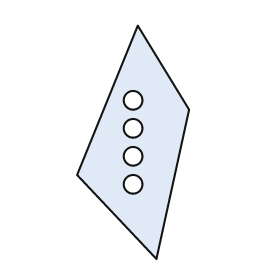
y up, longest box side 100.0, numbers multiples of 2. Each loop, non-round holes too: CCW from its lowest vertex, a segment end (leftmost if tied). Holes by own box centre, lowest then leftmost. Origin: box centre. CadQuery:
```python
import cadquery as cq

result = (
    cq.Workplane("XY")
    .moveTo(10.0, -50.0)
    .lineTo(24.0, 14.0)
    .lineTo(2.0, 50.0)
    .lineTo(-24.0, -14.0)
    .close()
    .moveTo(0.0, -18.0)
    .circle(4.0)
    .moveTo(0.0, -6.0)
    .circle(4.0)
    .moveTo(0.0, 6.0)
    .circle(4.0)
    .moveTo(0.0, 18.0)
    .circle(4.0)
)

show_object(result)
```